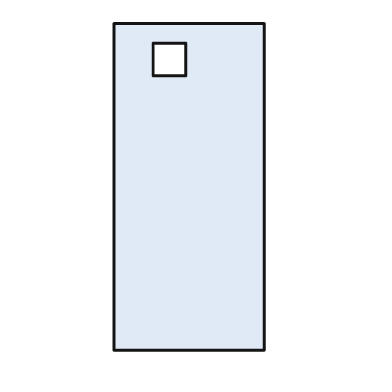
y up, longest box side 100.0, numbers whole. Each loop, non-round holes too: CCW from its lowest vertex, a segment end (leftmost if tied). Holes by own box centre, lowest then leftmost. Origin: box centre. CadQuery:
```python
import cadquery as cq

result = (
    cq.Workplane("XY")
    .moveTo(-23.0, -50.0)
    .lineTo(23.0, -50.0)
    .lineTo(23.0, 50.0)
    .lineTo(-23.0, 50.0)
    .close()
    .moveTo(-11.0, 34.0)
    .lineTo(-1.0, 34.0)
    .lineTo(-1.0, 44.0)
    .lineTo(-11.0, 44.0)
    .close()
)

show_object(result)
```